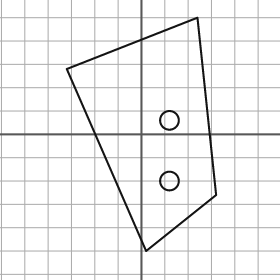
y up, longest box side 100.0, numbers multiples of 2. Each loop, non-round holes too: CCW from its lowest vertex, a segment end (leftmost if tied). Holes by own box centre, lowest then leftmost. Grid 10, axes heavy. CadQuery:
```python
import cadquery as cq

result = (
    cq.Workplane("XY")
    .moveTo(2.0, -50.0)
    .lineTo(32.0, -26.0)
    .lineTo(24.0, 50.0)
    .lineTo(-32.0, 28.0)
    .close()
    .moveTo(12.0, -20.0)
    .circle(4.0)
    .moveTo(12.0, 6.0)
    .circle(4.0)
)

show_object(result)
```